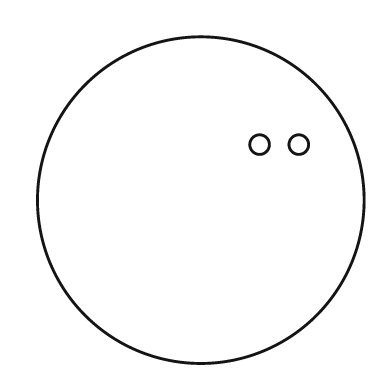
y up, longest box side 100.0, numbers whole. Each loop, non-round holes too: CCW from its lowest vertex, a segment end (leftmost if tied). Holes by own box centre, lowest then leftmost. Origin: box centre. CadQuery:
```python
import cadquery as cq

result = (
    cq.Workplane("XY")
    .moveTo(0.0, 0.0)
    .circle(50.0)
    .moveTo(18.0, 17.0)
    .circle(3.0)
    .moveTo(30.0, 17.0)
    .circle(3.0)
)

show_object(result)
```